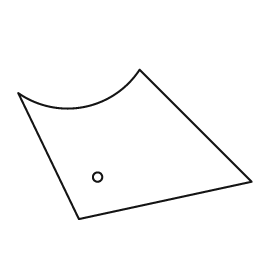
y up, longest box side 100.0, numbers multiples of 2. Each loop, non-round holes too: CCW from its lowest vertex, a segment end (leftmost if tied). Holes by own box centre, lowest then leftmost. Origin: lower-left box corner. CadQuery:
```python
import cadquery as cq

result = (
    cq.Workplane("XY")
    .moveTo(26.0, 0.0)
    .lineTo(100.0, 16.0)
    .lineTo(52.0, 64.0)
    .threePointArc((28.0, 48.0), (0.0, 54.0))
    .close()
    .moveTo(34.0, 18.0)
    .circle(2.0)
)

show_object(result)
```